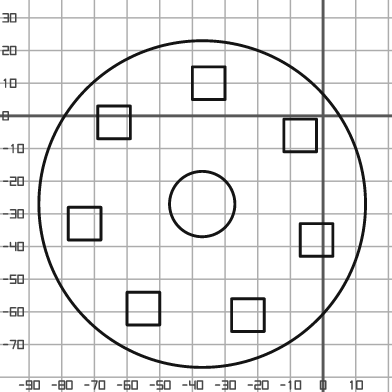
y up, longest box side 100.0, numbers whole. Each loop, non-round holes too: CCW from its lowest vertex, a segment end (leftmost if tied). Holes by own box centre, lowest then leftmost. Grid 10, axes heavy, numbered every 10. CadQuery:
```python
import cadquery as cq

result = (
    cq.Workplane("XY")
    .moveTo(-37.0, -27.0)
    .circle(50.0)
    .moveTo(-28.0, -66.0)
    .lineTo(-18.0, -66.0)
    .lineTo(-18.0, -56.0)
    .lineTo(-28.0, -56.0)
    .close()
    .moveTo(-60.0, -64.0)
    .lineTo(-50.0, -64.0)
    .lineTo(-50.0, -54.0)
    .lineTo(-60.0, -54.0)
    .close()
    .moveTo(-7.0, -43.0)
    .lineTo(3.0, -43.0)
    .lineTo(3.0, -33.0)
    .lineTo(-7.0, -33.0)
    .close()
    .moveTo(-78.0, -38.0)
    .lineTo(-68.0, -38.0)
    .lineTo(-68.0, -28.0)
    .lineTo(-78.0, -28.0)
    .close()
    .moveTo(-37.0, -27.0)
    .circle(10.0)
    .moveTo(-12.0, -11.0)
    .lineTo(-2.0, -11.0)
    .lineTo(-2.0, -1.0)
    .lineTo(-12.0, -1.0)
    .close()
    .moveTo(-69.0, -7.0)
    .lineTo(-59.0, -7.0)
    .lineTo(-59.0, 3.0)
    .lineTo(-69.0, 3.0)
    .close()
    .moveTo(-40.0, 5.0)
    .lineTo(-30.0, 5.0)
    .lineTo(-30.0, 15.0)
    .lineTo(-40.0, 15.0)
    .close()
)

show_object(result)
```